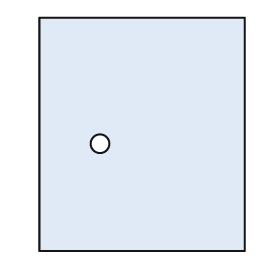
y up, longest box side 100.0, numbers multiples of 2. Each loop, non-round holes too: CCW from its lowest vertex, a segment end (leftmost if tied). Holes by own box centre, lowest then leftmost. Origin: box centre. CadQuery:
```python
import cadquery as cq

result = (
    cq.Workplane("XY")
    .moveTo(-44.0, -50.0)
    .lineTo(44.0, -50.0)
    .lineTo(44.0, 50.0)
    .lineTo(-44.0, 50.0)
    .close()
    .moveTo(-18.0, -4.0)
    .circle(4.0)
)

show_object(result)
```